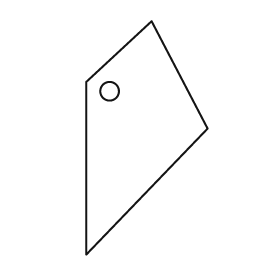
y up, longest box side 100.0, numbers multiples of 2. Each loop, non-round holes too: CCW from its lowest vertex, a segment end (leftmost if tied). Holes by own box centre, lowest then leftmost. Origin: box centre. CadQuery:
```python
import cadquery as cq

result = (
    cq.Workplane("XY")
    .moveTo(-26.0, -50.0)
    .lineTo(26.0, 4.0)
    .lineTo(2.0, 50.0)
    .lineTo(-26.0, 24.0)
    .close()
    .moveTo(-16.0, 20.0)
    .circle(4.0)
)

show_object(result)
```